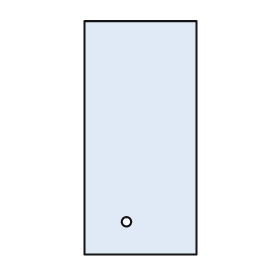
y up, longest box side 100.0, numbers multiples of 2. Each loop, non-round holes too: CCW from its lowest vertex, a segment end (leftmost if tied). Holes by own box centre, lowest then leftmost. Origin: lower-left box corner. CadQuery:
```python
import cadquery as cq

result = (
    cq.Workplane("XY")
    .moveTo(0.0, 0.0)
    .lineTo(48.0, 0.0)
    .lineTo(48.0, 100.0)
    .lineTo(0.0, 100.0)
    .close()
    .moveTo(18.0, 14.0)
    .circle(2.0)
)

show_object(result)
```